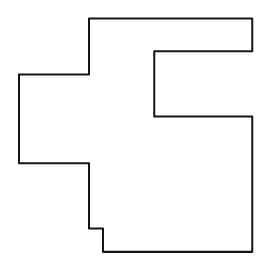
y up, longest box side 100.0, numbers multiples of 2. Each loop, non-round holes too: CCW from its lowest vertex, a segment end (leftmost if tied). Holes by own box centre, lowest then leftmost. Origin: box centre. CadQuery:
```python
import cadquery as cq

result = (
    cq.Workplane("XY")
    .moveTo(-14.0, -50.0)
    .lineTo(50.0, -50.0)
    .lineTo(50.0, 8.0)
    .lineTo(8.0, 8.0)
    .lineTo(8.0, 36.0)
    .lineTo(50.0, 36.0)
    .lineTo(50.0, 50.0)
    .lineTo(-20.0, 50.0)
    .lineTo(-20.0, 26.0)
    .lineTo(-50.0, 26.0)
    .lineTo(-50.0, -12.0)
    .lineTo(-20.0, -12.0)
    .lineTo(-20.0, -40.0)
    .lineTo(-14.0, -40.0)
    .close()
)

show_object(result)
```